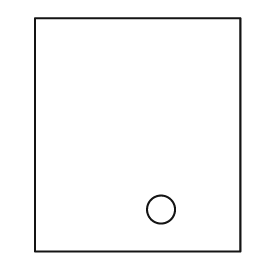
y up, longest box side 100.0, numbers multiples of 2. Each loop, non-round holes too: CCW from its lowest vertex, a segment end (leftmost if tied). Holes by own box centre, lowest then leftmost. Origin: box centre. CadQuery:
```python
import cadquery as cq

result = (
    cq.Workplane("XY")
    .moveTo(-44.0, -50.0)
    .lineTo(44.0, -50.0)
    .lineTo(44.0, 50.0)
    .lineTo(-44.0, 50.0)
    .close()
    .moveTo(10.0, -32.0)
    .circle(6.0)
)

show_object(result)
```